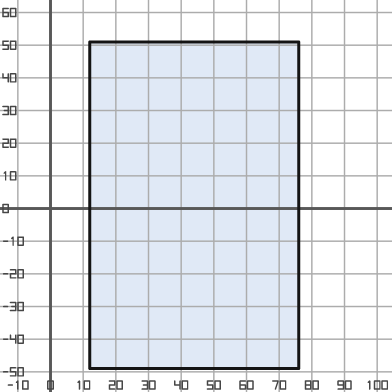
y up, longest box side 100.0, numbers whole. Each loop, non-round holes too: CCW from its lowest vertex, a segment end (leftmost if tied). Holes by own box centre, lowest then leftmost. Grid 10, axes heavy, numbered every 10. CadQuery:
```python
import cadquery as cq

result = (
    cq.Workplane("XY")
    .moveTo(12.0, -49.0)
    .lineTo(76.0, -49.0)
    .lineTo(76.0, 51.0)
    .lineTo(12.0, 51.0)
    .close()
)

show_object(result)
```